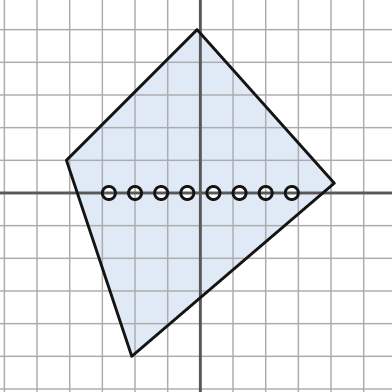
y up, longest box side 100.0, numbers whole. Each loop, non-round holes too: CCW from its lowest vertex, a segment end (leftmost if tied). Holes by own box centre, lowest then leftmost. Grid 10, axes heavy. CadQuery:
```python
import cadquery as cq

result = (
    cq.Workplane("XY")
    .moveTo(-21.0, -50.0)
    .lineTo(41.0, 3.0)
    .lineTo(-1.0, 50.0)
    .lineTo(-41.0, 10.0)
    .close()
    .moveTo(-28.0, 0.0)
    .circle(2.0)
    .moveTo(-20.0, 0.0)
    .circle(2.0)
    .moveTo(-12.0, 0.0)
    .circle(2.0)
    .moveTo(-4.0, 0.0)
    .circle(2.0)
    .moveTo(4.0, 0.0)
    .circle(2.0)
    .moveTo(12.0, 0.0)
    .circle(2.0)
    .moveTo(20.0, 0.0)
    .circle(2.0)
    .moveTo(28.0, 0.0)
    .circle(2.0)
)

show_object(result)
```